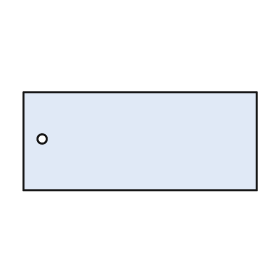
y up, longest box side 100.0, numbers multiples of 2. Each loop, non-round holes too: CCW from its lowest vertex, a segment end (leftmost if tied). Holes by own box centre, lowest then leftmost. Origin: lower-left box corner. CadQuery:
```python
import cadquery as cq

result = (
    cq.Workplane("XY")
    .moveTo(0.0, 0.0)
    .lineTo(100.0, 0.0)
    .lineTo(100.0, 42.0)
    .lineTo(0.0, 42.0)
    .close()
    .moveTo(8.0, 22.0)
    .circle(2.0)
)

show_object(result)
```